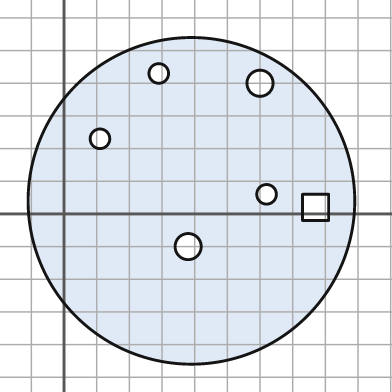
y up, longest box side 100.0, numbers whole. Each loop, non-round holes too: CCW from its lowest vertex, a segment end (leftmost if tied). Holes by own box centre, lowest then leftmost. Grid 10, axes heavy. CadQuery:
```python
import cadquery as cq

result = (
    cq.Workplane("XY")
    .moveTo(39.0, 4.0)
    .circle(50.0)
    .moveTo(38.0, -10.0)
    .circle(4.0)
    .moveTo(73.0, -2.0)
    .lineTo(81.0, -2.0)
    .lineTo(81.0, 6.0)
    .lineTo(73.0, 6.0)
    .close()
    .moveTo(62.0, 6.0)
    .circle(3.0)
    .moveTo(11.0, 23.0)
    .circle(3.0)
    .moveTo(60.0, 40.0)
    .circle(4.0)
    .moveTo(29.0, 43.0)
    .circle(3.0)
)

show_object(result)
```